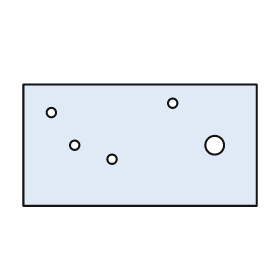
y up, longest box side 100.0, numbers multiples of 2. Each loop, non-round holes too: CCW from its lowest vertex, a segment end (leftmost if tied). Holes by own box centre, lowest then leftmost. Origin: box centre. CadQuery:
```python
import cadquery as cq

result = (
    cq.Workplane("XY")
    .moveTo(-50.0, -26.0)
    .lineTo(50.0, -26.0)
    .lineTo(50.0, 26.0)
    .lineTo(-50.0, 26.0)
    .close()
    .moveTo(-12.0, -6.0)
    .circle(2.0)
    .moveTo(-28.0, 0.0)
    .circle(2.0)
    .moveTo(32.0, 0.0)
    .circle(4.0)
    .moveTo(-38.0, 14.0)
    .circle(2.0)
    .moveTo(14.0, 18.0)
    .circle(2.0)
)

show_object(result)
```